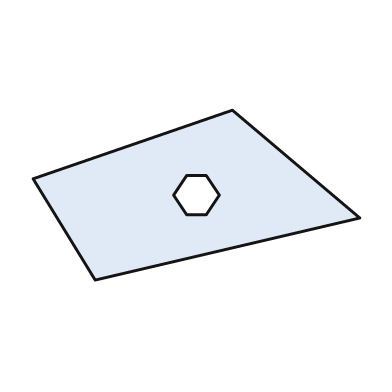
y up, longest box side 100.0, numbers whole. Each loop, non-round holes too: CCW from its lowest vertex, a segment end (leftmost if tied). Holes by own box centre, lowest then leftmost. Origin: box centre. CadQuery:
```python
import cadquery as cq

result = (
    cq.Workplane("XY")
    .moveTo(-31.0, -26.0)
    .lineTo(50.0, -7.0)
    .lineTo(11.0, 26.0)
    .lineTo(-50.0, 5.0)
    .close()
    .moveTo(-3.0, -6.0)
    .lineTo(3.0, -6.0)
    .lineTo(7.0, 0.0)
    .lineTo(3.0, 6.0)
    .lineTo(-3.0, 6.0)
    .lineTo(-7.0, 0.0)
    .close()
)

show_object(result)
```